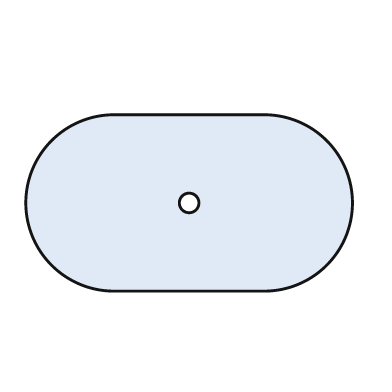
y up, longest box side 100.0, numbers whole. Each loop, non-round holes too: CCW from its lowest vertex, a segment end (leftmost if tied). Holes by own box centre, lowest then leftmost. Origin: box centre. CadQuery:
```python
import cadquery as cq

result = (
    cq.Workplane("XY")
    .moveTo(-23.0, -27.0)
    .lineTo(23.0, -27.0)
    .threePointArc((50.0, 0.0), (23.0, 27.0))
    .lineTo(-23.0, 27.0)
    .threePointArc((-50.0, 0.0), (-23.0, -27.0))
    .close()
    .moveTo(0.0, 0.0)
    .circle(3.0)
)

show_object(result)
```